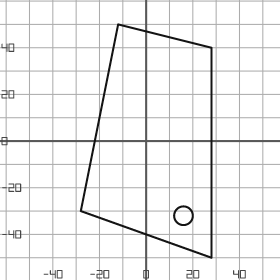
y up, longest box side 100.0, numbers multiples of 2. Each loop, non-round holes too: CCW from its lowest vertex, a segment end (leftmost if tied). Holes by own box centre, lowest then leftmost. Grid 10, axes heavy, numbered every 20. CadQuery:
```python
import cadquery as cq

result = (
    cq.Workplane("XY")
    .moveTo(28.0, -50.0)
    .lineTo(28.0, 40.0)
    .lineTo(-12.0, 50.0)
    .lineTo(-28.0, -30.0)
    .close()
    .moveTo(16.0, -32.0)
    .circle(4.0)
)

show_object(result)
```